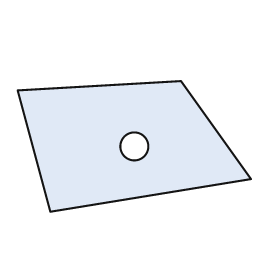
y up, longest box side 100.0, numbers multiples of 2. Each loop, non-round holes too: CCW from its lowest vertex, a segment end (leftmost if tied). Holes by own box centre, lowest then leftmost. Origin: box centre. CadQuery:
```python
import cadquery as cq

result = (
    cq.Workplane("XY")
    .moveTo(-36.0, -28.0)
    .lineTo(50.0, -14.0)
    .lineTo(20.0, 28.0)
    .lineTo(-50.0, 24.0)
    .close()
    .moveTo(0.0, 0.0)
    .circle(6.0)
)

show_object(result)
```